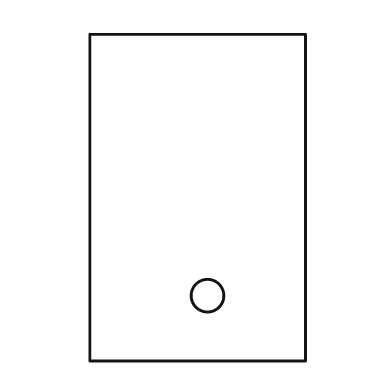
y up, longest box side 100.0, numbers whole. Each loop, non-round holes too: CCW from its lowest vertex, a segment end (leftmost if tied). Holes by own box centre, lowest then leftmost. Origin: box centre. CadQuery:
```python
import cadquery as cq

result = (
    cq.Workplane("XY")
    .moveTo(-33.0, -50.0)
    .lineTo(33.0, -50.0)
    .lineTo(33.0, 50.0)
    .lineTo(-33.0, 50.0)
    .close()
    .moveTo(3.0, -30.0)
    .circle(5.0)
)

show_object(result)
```